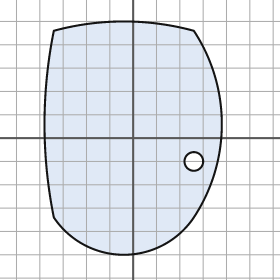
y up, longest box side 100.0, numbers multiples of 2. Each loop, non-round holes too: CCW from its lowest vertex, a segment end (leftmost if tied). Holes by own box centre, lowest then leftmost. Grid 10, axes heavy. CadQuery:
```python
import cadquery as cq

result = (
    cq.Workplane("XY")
    .moveTo(-34.0, -34.0)
    .threePointArc((-4.0, -50.0), (26.0, -34.0))
    .threePointArc((38.0, 6.0), (26.0, 46.0))
    .threePointArc((-4.0, 50.0), (-34.0, 46.0))
    .threePointArc((-38.0, 6.0), (-34.0, -34.0))
    .close()
    .moveTo(26.0, -10.0)
    .circle(4.0)
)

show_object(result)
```